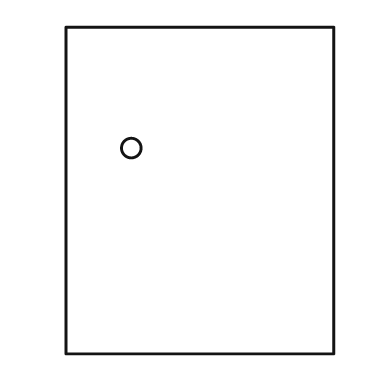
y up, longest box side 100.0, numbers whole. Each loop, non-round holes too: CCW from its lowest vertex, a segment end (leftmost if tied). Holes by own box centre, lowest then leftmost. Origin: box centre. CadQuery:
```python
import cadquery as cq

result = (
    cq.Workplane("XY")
    .moveTo(-41.0, -50.0)
    .lineTo(41.0, -50.0)
    .lineTo(41.0, 50.0)
    .lineTo(-41.0, 50.0)
    .close()
    .moveTo(-21.0, 13.0)
    .circle(3.0)
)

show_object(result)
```